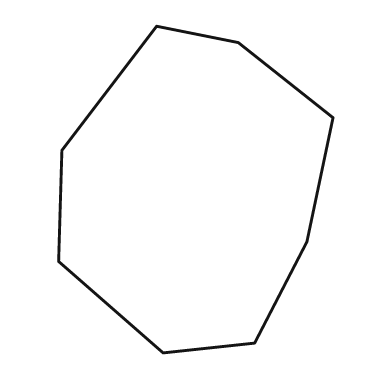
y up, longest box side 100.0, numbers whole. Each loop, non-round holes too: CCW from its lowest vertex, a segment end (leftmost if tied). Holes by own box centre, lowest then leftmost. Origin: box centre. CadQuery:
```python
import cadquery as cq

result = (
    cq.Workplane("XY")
    .moveTo(-10.0, -50.0)
    .lineTo(18.0, -47.0)
    .lineTo(34.0, -16.0)
    .lineTo(42.0, 22.0)
    .lineTo(13.0, 45.0)
    .lineTo(-12.0, 50.0)
    .lineTo(-41.0, 12.0)
    .lineTo(-42.0, -22.0)
    .close()
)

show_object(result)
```